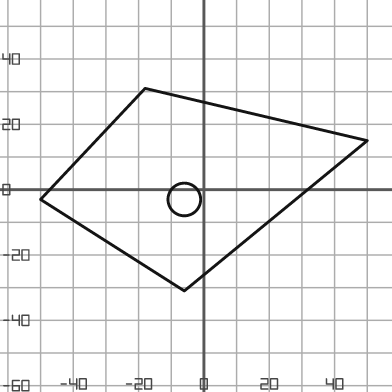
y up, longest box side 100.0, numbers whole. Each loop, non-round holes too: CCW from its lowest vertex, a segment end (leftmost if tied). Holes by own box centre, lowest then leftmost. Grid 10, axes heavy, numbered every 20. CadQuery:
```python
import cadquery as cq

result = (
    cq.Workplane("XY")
    .moveTo(-6.0, -31.0)
    .lineTo(50.0, 15.0)
    .lineTo(-18.0, 31.0)
    .lineTo(-50.0, -3.0)
    .close()
    .moveTo(-6.0, -3.0)
    .circle(5.0)
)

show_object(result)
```